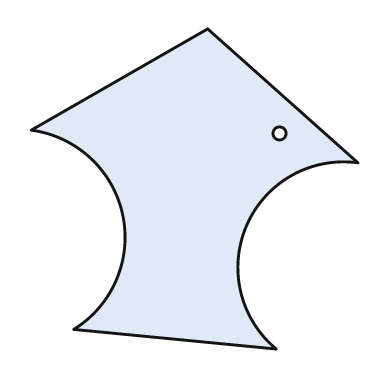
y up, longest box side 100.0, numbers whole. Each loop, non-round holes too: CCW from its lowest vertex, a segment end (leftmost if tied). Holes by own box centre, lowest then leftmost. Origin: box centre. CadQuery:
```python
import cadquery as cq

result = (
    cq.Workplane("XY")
    .moveTo(25.0, -49.0)
    .threePointArc((16.0, -11.0), (50.0, 8.0))
    .lineTo(4.0, 49.0)
    .lineTo(-50.0, 18.0)
    .threePointArc((-22.0, -8.0), (-37.0, -43.0))
    .close()
    .moveTo(26.0, 17.0)
    .circle(2.0)
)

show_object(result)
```